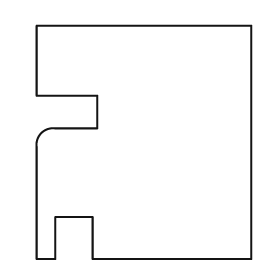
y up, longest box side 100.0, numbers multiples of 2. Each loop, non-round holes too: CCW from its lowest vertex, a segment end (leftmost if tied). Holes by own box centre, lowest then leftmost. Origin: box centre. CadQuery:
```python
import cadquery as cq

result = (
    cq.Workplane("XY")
    .moveTo(-46.0, -50.0)
    .lineTo(-38.0, -50.0)
    .lineTo(-38.0, -32.0)
    .lineTo(-22.0, -32.0)
    .lineTo(-22.0, -50.0)
    .lineTo(46.0, -50.0)
    .lineTo(46.0, 50.0)
    .lineTo(-46.0, 50.0)
    .lineTo(-46.0, 20.0)
    .lineTo(-20.0, 20.0)
    .lineTo(-20.0, 6.0)
    .lineTo(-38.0, 6.0)
    .threePointArc((-44.0, 4.0), (-46.0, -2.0))
    .close()
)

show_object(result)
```